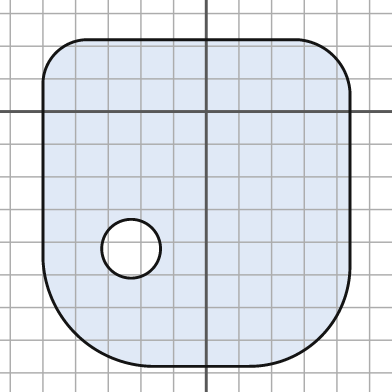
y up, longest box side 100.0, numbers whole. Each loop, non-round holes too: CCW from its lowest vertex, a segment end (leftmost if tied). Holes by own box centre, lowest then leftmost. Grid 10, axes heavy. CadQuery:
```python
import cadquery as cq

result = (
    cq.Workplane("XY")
    .moveTo(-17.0, -78.0)
    .lineTo(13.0, -78.0)
    .threePointArc((35.0, -69.0), (44.0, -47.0))
    .lineTo(44.0, 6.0)
    .threePointArc((39.0, 17.0), (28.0, 22.0))
    .lineTo(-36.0, 22.0)
    .threePointArc((-46.0, 18.0), (-50.0, 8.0))
    .lineTo(-50.0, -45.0)
    .threePointArc((-40.0, -68.0), (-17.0, -78.0))
    .close()
    .moveTo(-23.0, -42.0)
    .circle(9.0)
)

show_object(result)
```